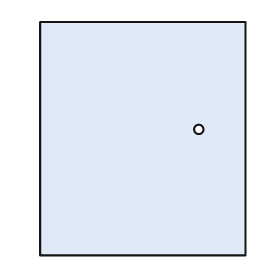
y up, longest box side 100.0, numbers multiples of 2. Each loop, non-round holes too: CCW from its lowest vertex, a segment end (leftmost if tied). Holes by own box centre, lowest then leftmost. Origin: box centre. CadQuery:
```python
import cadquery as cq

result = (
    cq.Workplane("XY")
    .moveTo(-44.0, -50.0)
    .lineTo(44.0, -50.0)
    .lineTo(44.0, 50.0)
    .lineTo(-44.0, 50.0)
    .close()
    .moveTo(24.0, 4.0)
    .circle(2.0)
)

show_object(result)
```